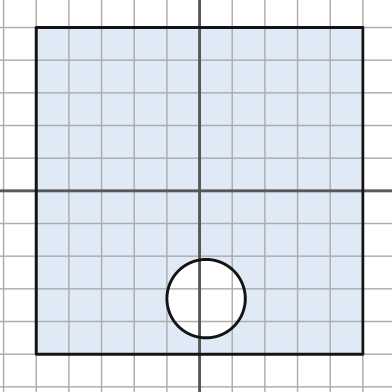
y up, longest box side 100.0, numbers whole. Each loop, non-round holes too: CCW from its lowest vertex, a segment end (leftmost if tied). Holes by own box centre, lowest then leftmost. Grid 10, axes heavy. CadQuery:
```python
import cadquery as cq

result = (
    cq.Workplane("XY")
    .moveTo(-50.0, -50.0)
    .lineTo(50.0, -50.0)
    .lineTo(50.0, 50.0)
    .lineTo(-50.0, 50.0)
    .close()
    .moveTo(2.0, -33.0)
    .circle(12.0)
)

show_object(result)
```